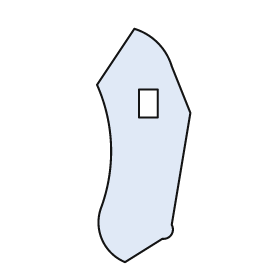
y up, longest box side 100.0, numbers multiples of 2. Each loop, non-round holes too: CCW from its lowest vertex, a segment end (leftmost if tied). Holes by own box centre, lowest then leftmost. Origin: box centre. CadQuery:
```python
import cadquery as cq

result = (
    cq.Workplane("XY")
    .moveTo(-8.0, -50.0)
    .lineTo(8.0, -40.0)
    .threePointArc((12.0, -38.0), (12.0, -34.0))
    .lineTo(20.0, 14.0)
    .lineTo(12.0, 34.0)
    .threePointArc((6.0, 44.0), (-4.0, 50.0))
    .lineTo(-20.0, 26.0)
    .threePointArc((-14.0, 0.0), (-18.0, -26.0))
    .threePointArc((-18.0, -40.0), (-8.0, -50.0))
    .close()
    .moveTo(-2.0, 12.0)
    .lineTo(6.0, 12.0)
    .lineTo(6.0, 24.0)
    .lineTo(-2.0, 24.0)
    .close()
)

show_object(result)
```